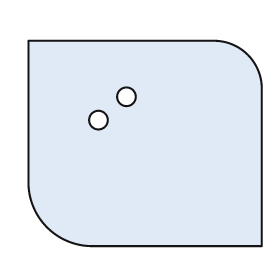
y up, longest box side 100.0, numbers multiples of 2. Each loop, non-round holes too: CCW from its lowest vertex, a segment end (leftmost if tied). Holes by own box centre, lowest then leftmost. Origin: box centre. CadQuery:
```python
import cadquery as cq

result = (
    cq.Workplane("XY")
    .moveTo(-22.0, -44.0)
    .lineTo(50.0, -44.0)
    .lineTo(50.0, 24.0)
    .threePointArc((44.0, 38.0), (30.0, 44.0))
    .lineTo(-50.0, 44.0)
    .lineTo(-50.0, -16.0)
    .threePointArc((-42.0, -36.0), (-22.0, -44.0))
    .close()
    .moveTo(-20.0, 10.0)
    .circle(4.0)
    .moveTo(-8.0, 20.0)
    .circle(4.0)
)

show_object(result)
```